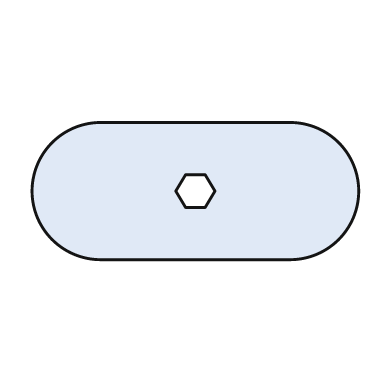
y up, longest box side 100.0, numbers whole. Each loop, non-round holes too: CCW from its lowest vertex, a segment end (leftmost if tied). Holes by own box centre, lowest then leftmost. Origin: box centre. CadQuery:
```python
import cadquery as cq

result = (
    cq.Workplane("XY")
    .moveTo(-29.0, -21.0)
    .lineTo(29.0, -21.0)
    .threePointArc((50.0, 0.0), (29.0, 21.0))
    .lineTo(-29.0, 21.0)
    .threePointArc((-50.0, 0.0), (-29.0, -21.0))
    .close()
    .moveTo(-3.0, -5.0)
    .lineTo(3.0, -5.0)
    .lineTo(6.0, 0.0)
    .lineTo(3.0, 5.0)
    .lineTo(-3.0, 5.0)
    .lineTo(-6.0, 0.0)
    .close()
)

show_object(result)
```